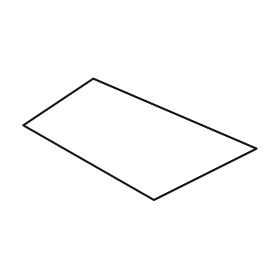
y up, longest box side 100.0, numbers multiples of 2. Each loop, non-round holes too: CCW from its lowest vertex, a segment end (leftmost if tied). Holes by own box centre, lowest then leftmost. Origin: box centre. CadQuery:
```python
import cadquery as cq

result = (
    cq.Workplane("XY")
    .moveTo(6.0, -26.0)
    .lineTo(50.0, -4.0)
    .lineTo(-20.0, 26.0)
    .lineTo(-50.0, 6.0)
    .close()
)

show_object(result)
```